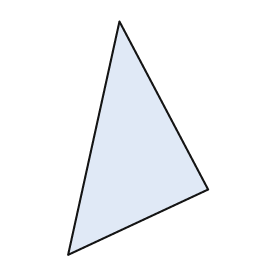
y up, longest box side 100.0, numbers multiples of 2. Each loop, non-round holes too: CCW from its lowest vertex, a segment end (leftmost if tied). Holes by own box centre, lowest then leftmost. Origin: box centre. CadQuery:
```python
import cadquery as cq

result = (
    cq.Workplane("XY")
    .moveTo(-30.0, -50.0)
    .lineTo(30.0, -22.0)
    .lineTo(-8.0, 50.0)
    .close()
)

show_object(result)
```